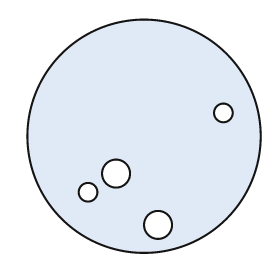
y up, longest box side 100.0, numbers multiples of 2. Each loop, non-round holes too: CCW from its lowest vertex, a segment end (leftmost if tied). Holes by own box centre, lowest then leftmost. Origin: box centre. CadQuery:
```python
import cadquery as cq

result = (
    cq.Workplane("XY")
    .moveTo(0.0, 0.0)
    .circle(50.0)
    .moveTo(6.0, -38.0)
    .circle(6.0)
    .moveTo(-24.0, -24.0)
    .circle(4.0)
    .moveTo(-12.0, -16.0)
    .circle(6.0)
    .moveTo(34.0, 10.0)
    .circle(4.0)
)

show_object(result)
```